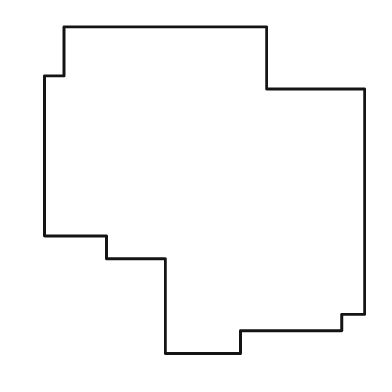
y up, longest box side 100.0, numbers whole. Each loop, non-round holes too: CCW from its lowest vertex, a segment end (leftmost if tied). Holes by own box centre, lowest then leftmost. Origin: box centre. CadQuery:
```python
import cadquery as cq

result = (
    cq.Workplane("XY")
    .moveTo(-12.0, -50.0)
    .lineTo(11.0, -50.0)
    .lineTo(11.0, -43.0)
    .lineTo(42.0, -43.0)
    .lineTo(42.0, -38.0)
    .lineTo(49.0, -38.0)
    .lineTo(49.0, 31.0)
    .lineTo(19.0, 31.0)
    .lineTo(19.0, 50.0)
    .lineTo(-43.0, 50.0)
    .lineTo(-43.0, 35.0)
    .lineTo(-49.0, 35.0)
    .lineTo(-49.0, -14.0)
    .lineTo(-30.0, -14.0)
    .lineTo(-30.0, -21.0)
    .lineTo(-12.0, -21.0)
    .close()
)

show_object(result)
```